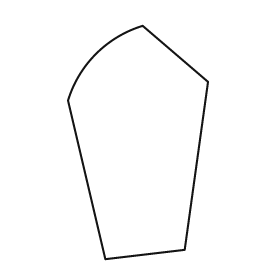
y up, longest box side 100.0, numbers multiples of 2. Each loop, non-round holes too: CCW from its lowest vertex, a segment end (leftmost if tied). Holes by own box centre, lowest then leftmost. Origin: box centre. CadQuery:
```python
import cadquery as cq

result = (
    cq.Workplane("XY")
    .moveTo(-14.0, -50.0)
    .lineTo(20.0, -46.0)
    .lineTo(30.0, 26.0)
    .lineTo(2.0, 50.0)
    .threePointArc((-18.0, 38.0), (-30.0, 18.0))
    .close()
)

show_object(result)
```